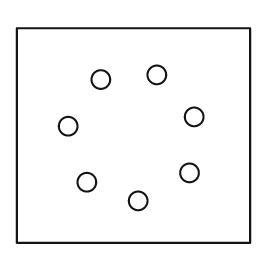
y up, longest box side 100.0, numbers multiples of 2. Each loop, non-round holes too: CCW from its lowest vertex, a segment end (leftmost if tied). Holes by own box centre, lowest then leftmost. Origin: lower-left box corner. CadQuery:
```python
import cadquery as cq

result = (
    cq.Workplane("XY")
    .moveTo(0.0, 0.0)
    .lineTo(100.0, 0.0)
    .lineTo(100.0, 92.0)
    .lineTo(0.0, 92.0)
    .close()
    .moveTo(52.0, 18.0)
    .circle(4.0)
    .moveTo(30.0, 26.0)
    .circle(4.0)
    .moveTo(74.0, 30.0)
    .circle(4.0)
    .moveTo(22.0, 50.0)
    .circle(4.0)
    .moveTo(76.0, 54.0)
    .circle(4.0)
    .moveTo(36.0, 70.0)
    .circle(4.0)
    .moveTo(60.0, 72.0)
    .circle(4.0)
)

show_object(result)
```